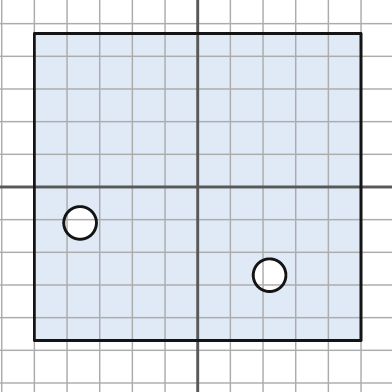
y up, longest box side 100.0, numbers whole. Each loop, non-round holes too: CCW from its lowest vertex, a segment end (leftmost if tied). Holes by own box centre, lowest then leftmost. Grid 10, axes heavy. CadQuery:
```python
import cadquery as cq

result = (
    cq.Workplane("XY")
    .moveTo(-50.0, -47.0)
    .lineTo(50.0, -47.0)
    .lineTo(50.0, 47.0)
    .lineTo(-50.0, 47.0)
    .close()
    .moveTo(22.0, -27.0)
    .circle(5.0)
    .moveTo(-36.0, -11.0)
    .circle(5.0)
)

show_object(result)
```